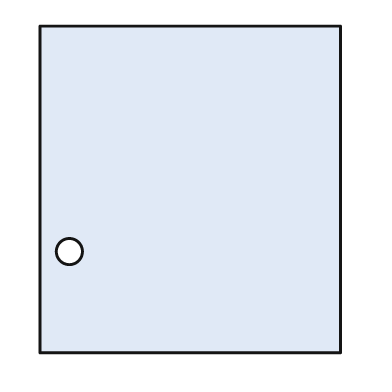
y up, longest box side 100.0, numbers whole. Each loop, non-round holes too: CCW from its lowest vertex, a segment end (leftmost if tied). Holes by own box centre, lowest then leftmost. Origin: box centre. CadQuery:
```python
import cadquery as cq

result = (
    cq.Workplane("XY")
    .moveTo(-46.0, -50.0)
    .lineTo(46.0, -50.0)
    .lineTo(46.0, 50.0)
    .lineTo(-46.0, 50.0)
    .close()
    .moveTo(-37.0, -19.0)
    .circle(4.0)
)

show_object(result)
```